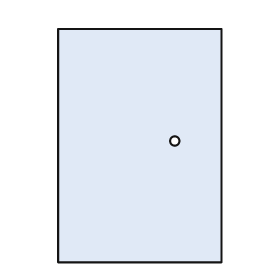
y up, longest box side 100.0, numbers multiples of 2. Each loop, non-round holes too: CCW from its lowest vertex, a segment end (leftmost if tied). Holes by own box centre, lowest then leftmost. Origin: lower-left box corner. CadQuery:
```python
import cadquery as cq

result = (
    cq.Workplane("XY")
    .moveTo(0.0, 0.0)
    .lineTo(70.0, 0.0)
    .lineTo(70.0, 100.0)
    .lineTo(0.0, 100.0)
    .close()
    .moveTo(50.0, 52.0)
    .circle(2.0)
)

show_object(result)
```